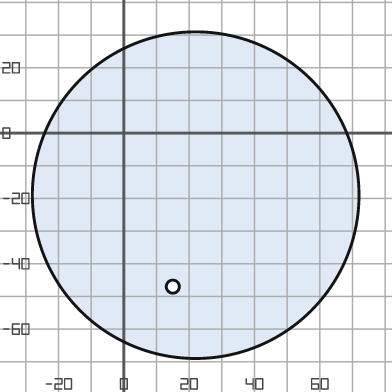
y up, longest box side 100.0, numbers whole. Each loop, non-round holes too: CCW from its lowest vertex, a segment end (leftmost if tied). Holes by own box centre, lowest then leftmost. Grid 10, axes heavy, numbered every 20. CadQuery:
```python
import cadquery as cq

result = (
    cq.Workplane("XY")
    .moveTo(22.0, -19.0)
    .circle(50.0)
    .moveTo(15.0, -47.0)
    .circle(2.0)
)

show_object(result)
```